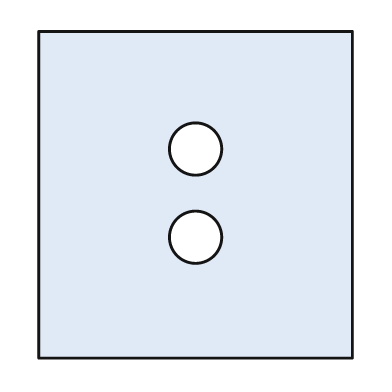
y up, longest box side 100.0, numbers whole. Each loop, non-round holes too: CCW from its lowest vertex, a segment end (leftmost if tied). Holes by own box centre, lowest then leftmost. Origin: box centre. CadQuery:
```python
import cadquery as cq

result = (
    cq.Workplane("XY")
    .moveTo(-48.0, -50.0)
    .lineTo(48.0, -50.0)
    .lineTo(48.0, 50.0)
    .lineTo(-48.0, 50.0)
    .close()
    .moveTo(0.0, -13.0)
    .circle(8.0)
    .moveTo(0.0, 14.0)
    .circle(8.0)
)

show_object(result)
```